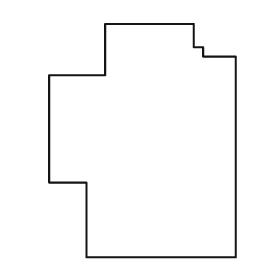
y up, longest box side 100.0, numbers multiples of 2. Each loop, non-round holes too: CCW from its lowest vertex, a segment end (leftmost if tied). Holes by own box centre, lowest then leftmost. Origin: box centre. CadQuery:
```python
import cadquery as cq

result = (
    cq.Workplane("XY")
    .moveTo(-24.0, -50.0)
    .lineTo(40.0, -50.0)
    .lineTo(40.0, 36.0)
    .lineTo(26.0, 36.0)
    .lineTo(26.0, 40.0)
    .lineTo(22.0, 40.0)
    .lineTo(22.0, 50.0)
    .lineTo(-16.0, 50.0)
    .lineTo(-16.0, 28.0)
    .lineTo(-40.0, 28.0)
    .lineTo(-40.0, -18.0)
    .lineTo(-24.0, -18.0)
    .close()
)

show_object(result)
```